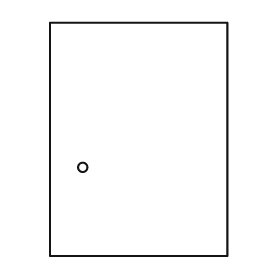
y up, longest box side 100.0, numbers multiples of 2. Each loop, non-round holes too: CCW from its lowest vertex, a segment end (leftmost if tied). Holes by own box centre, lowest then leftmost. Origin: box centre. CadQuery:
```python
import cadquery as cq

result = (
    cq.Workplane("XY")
    .moveTo(-38.0, -50.0)
    .lineTo(38.0, -50.0)
    .lineTo(38.0, 50.0)
    .lineTo(-38.0, 50.0)
    .close()
    .moveTo(-24.0, -12.0)
    .circle(2.0)
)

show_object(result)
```